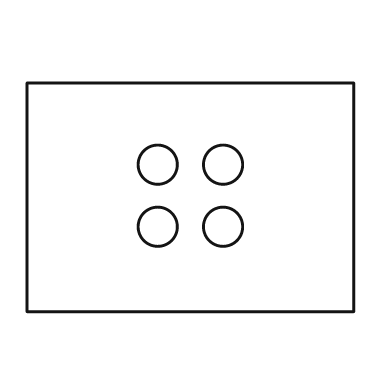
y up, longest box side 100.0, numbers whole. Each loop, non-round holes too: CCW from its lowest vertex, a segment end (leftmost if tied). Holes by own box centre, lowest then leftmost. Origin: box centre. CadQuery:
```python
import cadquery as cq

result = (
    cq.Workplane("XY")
    .moveTo(-50.0, -35.0)
    .lineTo(50.0, -35.0)
    .lineTo(50.0, 35.0)
    .lineTo(-50.0, 35.0)
    .close()
    .moveTo(-10.0, -9.0)
    .circle(6.0)
    .moveTo(10.0, -9.0)
    .circle(6.0)
    .moveTo(-10.0, 10.0)
    .circle(6.0)
    .moveTo(10.0, 10.0)
    .circle(6.0)
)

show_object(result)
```